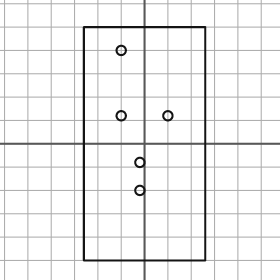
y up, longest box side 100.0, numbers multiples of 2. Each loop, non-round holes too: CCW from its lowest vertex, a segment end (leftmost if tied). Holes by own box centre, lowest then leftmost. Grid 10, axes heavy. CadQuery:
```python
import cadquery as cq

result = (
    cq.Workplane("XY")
    .moveTo(-26.0, -50.0)
    .lineTo(26.0, -50.0)
    .lineTo(26.0, 50.0)
    .lineTo(-26.0, 50.0)
    .close()
    .moveTo(-2.0, -20.0)
    .circle(2.0)
    .moveTo(-2.0, -8.0)
    .circle(2.0)
    .moveTo(-10.0, 12.0)
    .circle(2.0)
    .moveTo(10.0, 12.0)
    .circle(2.0)
    .moveTo(-10.0, 40.0)
    .circle(2.0)
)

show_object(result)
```